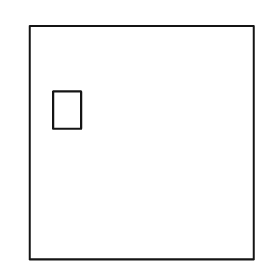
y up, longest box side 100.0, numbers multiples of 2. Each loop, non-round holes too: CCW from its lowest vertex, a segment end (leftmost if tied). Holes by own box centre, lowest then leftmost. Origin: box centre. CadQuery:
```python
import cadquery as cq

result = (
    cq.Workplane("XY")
    .moveTo(-48.0, -50.0)
    .lineTo(48.0, -50.0)
    .lineTo(48.0, 50.0)
    .lineTo(-48.0, 50.0)
    .close()
    .moveTo(-38.0, 6.0)
    .lineTo(-26.0, 6.0)
    .lineTo(-26.0, 22.0)
    .lineTo(-38.0, 22.0)
    .close()
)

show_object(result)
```